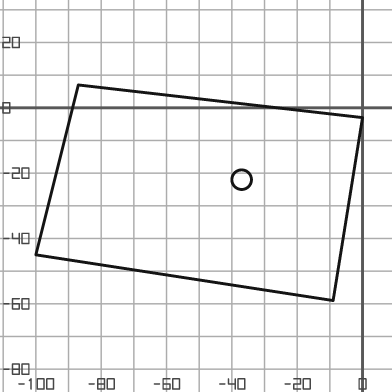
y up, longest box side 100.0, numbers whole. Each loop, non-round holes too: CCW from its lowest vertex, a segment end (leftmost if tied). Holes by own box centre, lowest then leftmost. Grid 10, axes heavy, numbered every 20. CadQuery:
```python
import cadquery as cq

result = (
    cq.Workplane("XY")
    .moveTo(-9.0, -59.0)
    .lineTo(0.0, -3.0)
    .lineTo(-87.0, 7.0)
    .lineTo(-100.0, -45.0)
    .close()
    .moveTo(-37.0, -22.0)
    .circle(3.0)
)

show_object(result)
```